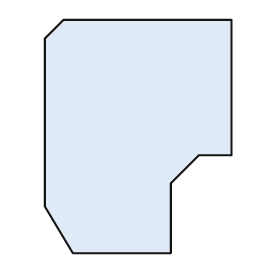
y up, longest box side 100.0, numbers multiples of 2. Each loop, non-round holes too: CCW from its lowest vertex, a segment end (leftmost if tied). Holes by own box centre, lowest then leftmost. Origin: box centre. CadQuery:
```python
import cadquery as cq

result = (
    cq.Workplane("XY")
    .moveTo(-28.0, -50.0)
    .lineTo(14.0, -50.0)
    .lineTo(14.0, -20.0)
    .lineTo(26.0, -8.0)
    .lineTo(40.0, -8.0)
    .lineTo(40.0, 50.0)
    .lineTo(-32.0, 50.0)
    .lineTo(-40.0, 42.0)
    .lineTo(-40.0, -30.0)
    .close()
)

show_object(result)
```